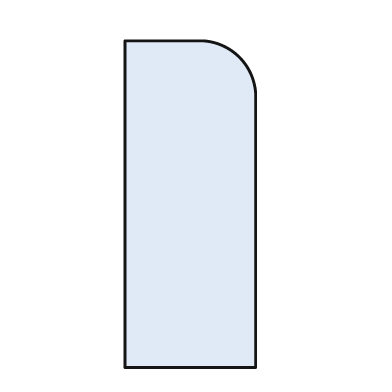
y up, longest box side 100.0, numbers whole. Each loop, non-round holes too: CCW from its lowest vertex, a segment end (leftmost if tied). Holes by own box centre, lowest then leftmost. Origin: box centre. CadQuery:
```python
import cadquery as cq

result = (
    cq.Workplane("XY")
    .moveTo(-20.0, -50.0)
    .lineTo(20.0, -50.0)
    .lineTo(20.0, 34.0)
    .threePointArc((15.0, 45.0), (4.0, 50.0))
    .lineTo(-20.0, 50.0)
    .close()
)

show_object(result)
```